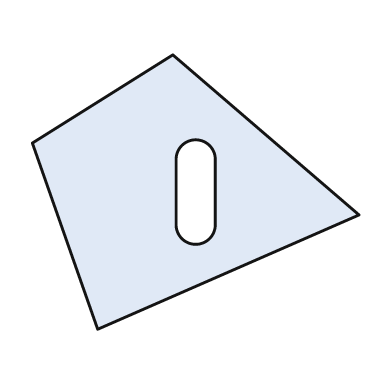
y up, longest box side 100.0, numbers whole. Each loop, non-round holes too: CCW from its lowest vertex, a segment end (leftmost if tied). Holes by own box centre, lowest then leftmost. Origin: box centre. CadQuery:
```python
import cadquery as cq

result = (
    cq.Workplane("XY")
    .moveTo(-30.0, -42.0)
    .lineTo(50.0, -7.0)
    .lineTo(-7.0, 42.0)
    .lineTo(-50.0, 15.0)
    .close()
    .moveTo(-6.0, -10.0)
    .threePointArc((0.0, -16.0), (6.0, -10.0))
    .lineTo(6.0, 10.0)
    .threePointArc((0.0, 16.0), (-6.0, 10.0))
    .close()
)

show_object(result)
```